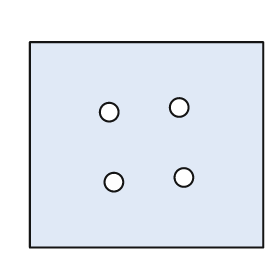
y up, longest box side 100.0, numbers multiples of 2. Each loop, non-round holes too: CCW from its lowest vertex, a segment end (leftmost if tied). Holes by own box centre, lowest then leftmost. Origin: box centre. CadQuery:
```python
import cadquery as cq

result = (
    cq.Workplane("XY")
    .moveTo(-50.0, -44.0)
    .lineTo(50.0, -44.0)
    .lineTo(50.0, 44.0)
    .lineTo(-50.0, 44.0)
    .close()
    .moveTo(-14.0, -16.0)
    .circle(4.0)
    .moveTo(16.0, -14.0)
    .circle(4.0)
    .moveTo(-16.0, 14.0)
    .circle(4.0)
    .moveTo(14.0, 16.0)
    .circle(4.0)
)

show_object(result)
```